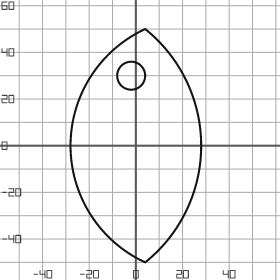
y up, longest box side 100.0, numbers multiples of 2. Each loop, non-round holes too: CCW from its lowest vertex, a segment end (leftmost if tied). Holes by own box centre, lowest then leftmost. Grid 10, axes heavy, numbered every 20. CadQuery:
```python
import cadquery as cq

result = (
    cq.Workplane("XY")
    .moveTo(4.0, -50.0)
    .threePointArc((28.0, 0.0), (4.0, 50.0))
    .threePointArc((-28.0, 0.0), (4.0, -50.0))
    .close()
    .moveTo(-2.0, 30.0)
    .circle(6.0)
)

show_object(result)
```